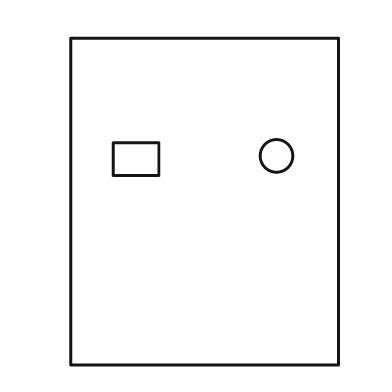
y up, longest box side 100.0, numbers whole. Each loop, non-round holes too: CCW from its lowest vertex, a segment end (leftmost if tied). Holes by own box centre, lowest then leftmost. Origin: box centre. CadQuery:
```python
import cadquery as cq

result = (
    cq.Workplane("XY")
    .moveTo(-41.0, -50.0)
    .lineTo(41.0, -50.0)
    .lineTo(41.0, 50.0)
    .lineTo(-41.0, 50.0)
    .close()
    .moveTo(-28.0, 8.0)
    .lineTo(-14.0, 8.0)
    .lineTo(-14.0, 18.0)
    .lineTo(-28.0, 18.0)
    .close()
    .moveTo(22.0, 14.0)
    .circle(5.0)
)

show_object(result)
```